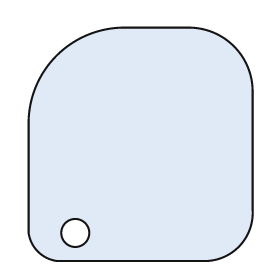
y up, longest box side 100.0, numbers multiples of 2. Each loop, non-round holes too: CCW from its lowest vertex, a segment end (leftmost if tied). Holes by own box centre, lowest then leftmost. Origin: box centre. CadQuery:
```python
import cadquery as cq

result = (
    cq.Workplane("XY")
    .moveTo(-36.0, -50.0)
    .lineTo(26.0, -50.0)
    .threePointArc((42.0, -44.0), (48.0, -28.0))
    .lineTo(48.0, 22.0)
    .threePointArc((40.0, 42.0), (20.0, 50.0))
    .lineTo(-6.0, 50.0)
    .threePointArc((-36.0, 38.0), (-48.0, 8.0))
    .lineTo(-48.0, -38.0)
    .threePointArc((-44.0, -46.0), (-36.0, -50.0))
    .close()
    .moveTo(-28.0, -38.0)
    .circle(6.0)
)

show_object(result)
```